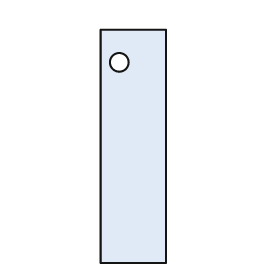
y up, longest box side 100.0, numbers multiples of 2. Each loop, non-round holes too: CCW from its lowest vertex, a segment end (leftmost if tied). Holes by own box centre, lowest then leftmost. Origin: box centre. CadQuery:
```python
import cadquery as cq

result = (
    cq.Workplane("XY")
    .moveTo(-14.0, -50.0)
    .lineTo(14.0, -50.0)
    .lineTo(14.0, 50.0)
    .lineTo(-14.0, 50.0)
    .close()
    .moveTo(-6.0, 36.0)
    .circle(4.0)
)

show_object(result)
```